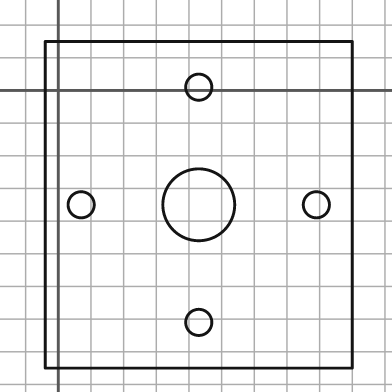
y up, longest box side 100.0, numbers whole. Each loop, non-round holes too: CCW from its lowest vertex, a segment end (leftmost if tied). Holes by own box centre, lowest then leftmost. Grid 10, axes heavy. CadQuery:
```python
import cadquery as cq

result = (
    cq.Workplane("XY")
    .moveTo(-4.0, -85.0)
    .lineTo(90.0, -85.0)
    .lineTo(90.0, 15.0)
    .lineTo(-4.0, 15.0)
    .close()
    .moveTo(43.0, -71.0)
    .circle(4.0)
    .moveTo(7.0, -35.0)
    .circle(4.0)
    .moveTo(43.0, -35.0)
    .circle(11.0)
    .moveTo(79.0, -35.0)
    .circle(4.0)
    .moveTo(43.0, 1.0)
    .circle(4.0)
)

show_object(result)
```